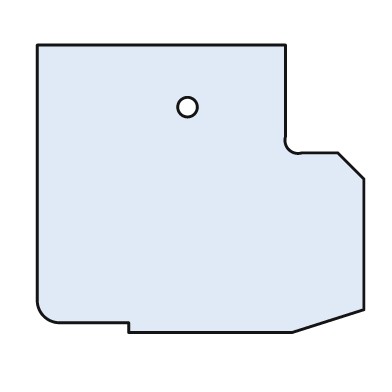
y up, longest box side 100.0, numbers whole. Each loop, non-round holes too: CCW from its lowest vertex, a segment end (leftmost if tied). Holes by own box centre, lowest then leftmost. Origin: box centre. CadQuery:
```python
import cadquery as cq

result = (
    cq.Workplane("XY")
    .moveTo(-22.0, -44.0)
    .lineTo(28.0, -44.0)
    .lineTo(50.0, -37.0)
    .lineTo(50.0, 3.0)
    .lineTo(42.0, 11.0)
    .lineTo(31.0, 11.0)
    .threePointArc((27.0, 12.0), (26.0, 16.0))
    .lineTo(26.0, 44.0)
    .lineTo(-50.0, 44.0)
    .lineTo(-50.0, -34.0)
    .threePointArc((-48.0, -39.0), (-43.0, -41.0))
    .lineTo(-22.0, -41.0)
    .close()
    .moveTo(-4.0, 25.0)
    .circle(3.0)
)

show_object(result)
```